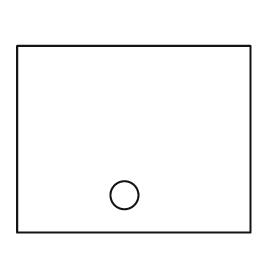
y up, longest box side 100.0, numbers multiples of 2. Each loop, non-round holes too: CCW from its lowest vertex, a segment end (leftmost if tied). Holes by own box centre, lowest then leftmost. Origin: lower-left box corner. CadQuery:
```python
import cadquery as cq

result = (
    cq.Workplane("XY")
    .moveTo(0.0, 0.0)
    .lineTo(100.0, 0.0)
    .lineTo(100.0, 80.0)
    .lineTo(0.0, 80.0)
    .close()
    .moveTo(46.0, 16.0)
    .circle(6.0)
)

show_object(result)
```